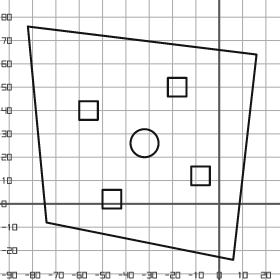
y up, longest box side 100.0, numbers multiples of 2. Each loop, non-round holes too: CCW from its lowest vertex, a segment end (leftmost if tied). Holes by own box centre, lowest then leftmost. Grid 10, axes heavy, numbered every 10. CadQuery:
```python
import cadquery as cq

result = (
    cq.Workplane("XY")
    .moveTo(6.0, -24.0)
    .lineTo(16.0, 64.0)
    .lineTo(-82.0, 76.0)
    .lineTo(-74.0, -8.0)
    .close()
    .moveTo(-50.0, -2.0)
    .lineTo(-42.0, -2.0)
    .lineTo(-42.0, 6.0)
    .lineTo(-50.0, 6.0)
    .close()
    .moveTo(-12.0, 8.0)
    .lineTo(-4.0, 8.0)
    .lineTo(-4.0, 16.0)
    .lineTo(-12.0, 16.0)
    .close()
    .moveTo(-32.0, 26.0)
    .circle(6.0)
    .moveTo(-60.0, 36.0)
    .lineTo(-52.0, 36.0)
    .lineTo(-52.0, 44.0)
    .lineTo(-60.0, 44.0)
    .close()
    .moveTo(-22.0, 46.0)
    .lineTo(-14.0, 46.0)
    .lineTo(-14.0, 54.0)
    .lineTo(-22.0, 54.0)
    .close()
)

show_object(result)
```